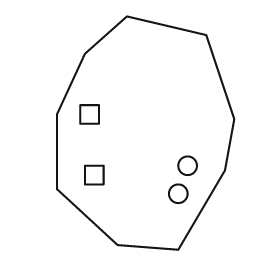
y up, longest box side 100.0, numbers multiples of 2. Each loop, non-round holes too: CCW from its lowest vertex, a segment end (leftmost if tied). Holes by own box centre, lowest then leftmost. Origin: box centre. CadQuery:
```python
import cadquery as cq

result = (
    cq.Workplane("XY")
    .moveTo(14.0, -50.0)
    .lineTo(34.0, -16.0)
    .lineTo(38.0, 6.0)
    .lineTo(26.0, 42.0)
    .lineTo(-8.0, 50.0)
    .lineTo(-26.0, 34.0)
    .lineTo(-38.0, 8.0)
    .lineTo(-38.0, -24.0)
    .lineTo(-12.0, -48.0)
    .close()
    .moveTo(14.0, -26.0)
    .circle(4.0)
    .moveTo(-26.0, -22.0)
    .lineTo(-18.0, -22.0)
    .lineTo(-18.0, -14.0)
    .lineTo(-26.0, -14.0)
    .close()
    .moveTo(18.0, -14.0)
    .circle(4.0)
    .moveTo(-28.0, 4.0)
    .lineTo(-20.0, 4.0)
    .lineTo(-20.0, 12.0)
    .lineTo(-28.0, 12.0)
    .close()
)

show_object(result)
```